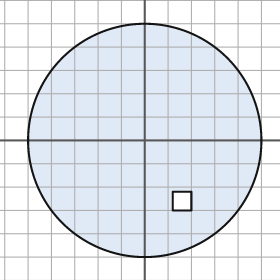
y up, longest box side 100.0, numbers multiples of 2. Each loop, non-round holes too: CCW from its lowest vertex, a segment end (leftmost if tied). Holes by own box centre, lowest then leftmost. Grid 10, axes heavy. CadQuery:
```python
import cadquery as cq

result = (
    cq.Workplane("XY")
    .moveTo(0.0, 0.0)
    .circle(50.0)
    .moveTo(12.0, -30.0)
    .lineTo(20.0, -30.0)
    .lineTo(20.0, -22.0)
    .lineTo(12.0, -22.0)
    .close()
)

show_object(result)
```